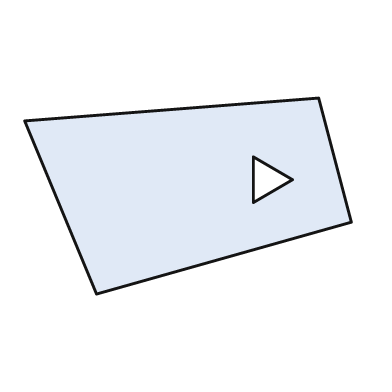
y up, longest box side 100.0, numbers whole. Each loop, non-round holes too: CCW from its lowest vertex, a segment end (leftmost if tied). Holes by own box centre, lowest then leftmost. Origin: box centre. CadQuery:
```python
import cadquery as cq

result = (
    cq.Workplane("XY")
    .moveTo(-28.0, -30.0)
    .lineTo(50.0, -8.0)
    .lineTo(40.0, 30.0)
    .lineTo(-50.0, 23.0)
    .close()
    .moveTo(20.0, -2.0)
    .lineTo(32.0, 5.0)
    .lineTo(20.0, 12.0)
    .close()
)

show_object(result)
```